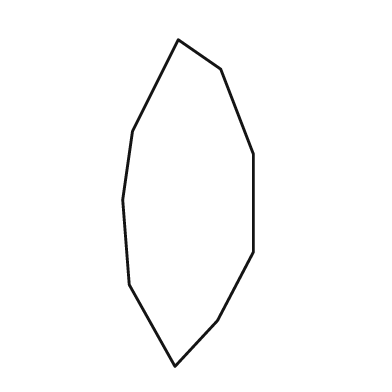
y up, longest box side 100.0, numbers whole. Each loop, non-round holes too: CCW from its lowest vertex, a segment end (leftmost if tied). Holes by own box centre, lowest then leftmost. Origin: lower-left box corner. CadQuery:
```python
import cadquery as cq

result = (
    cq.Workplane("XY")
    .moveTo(16.0, 0.0)
    .lineTo(29.0, 14.0)
    .lineTo(40.0, 35.0)
    .lineTo(40.0, 65.0)
    .lineTo(30.0, 91.0)
    .lineTo(17.0, 100.0)
    .lineTo(3.0, 72.0)
    .lineTo(0.0, 51.0)
    .lineTo(2.0, 25.0)
    .close()
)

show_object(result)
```